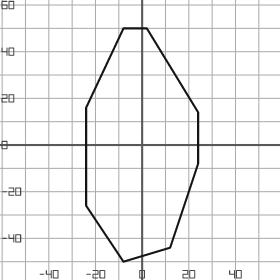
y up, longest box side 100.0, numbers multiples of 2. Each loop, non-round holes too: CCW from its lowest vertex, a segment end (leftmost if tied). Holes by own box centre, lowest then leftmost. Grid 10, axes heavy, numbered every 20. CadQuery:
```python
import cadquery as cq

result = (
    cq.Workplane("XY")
    .moveTo(-8.0, -50.0)
    .lineTo(12.0, -44.0)
    .lineTo(24.0, -8.0)
    .lineTo(24.0, 14.0)
    .lineTo(2.0, 50.0)
    .lineTo(-8.0, 50.0)
    .lineTo(-24.0, 16.0)
    .lineTo(-24.0, -26.0)
    .close()
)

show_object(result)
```